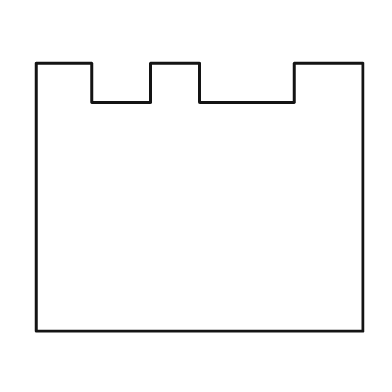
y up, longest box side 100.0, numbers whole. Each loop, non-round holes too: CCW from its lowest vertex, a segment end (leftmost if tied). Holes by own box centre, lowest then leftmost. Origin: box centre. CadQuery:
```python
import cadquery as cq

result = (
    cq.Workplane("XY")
    .moveTo(-50.0, -41.0)
    .lineTo(50.0, -41.0)
    .lineTo(50.0, 41.0)
    .lineTo(29.0, 41.0)
    .lineTo(29.0, 29.0)
    .lineTo(0.0, 29.0)
    .lineTo(0.0, 41.0)
    .lineTo(-15.0, 41.0)
    .lineTo(-15.0, 29.0)
    .lineTo(-33.0, 29.0)
    .lineTo(-33.0, 41.0)
    .lineTo(-50.0, 41.0)
    .close()
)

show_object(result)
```